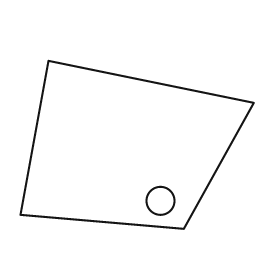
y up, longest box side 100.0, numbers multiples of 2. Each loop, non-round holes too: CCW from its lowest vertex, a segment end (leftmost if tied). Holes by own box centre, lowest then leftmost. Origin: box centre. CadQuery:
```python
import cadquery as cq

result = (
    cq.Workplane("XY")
    .moveTo(20.0, -36.0)
    .lineTo(50.0, 18.0)
    .lineTo(-38.0, 36.0)
    .lineTo(-50.0, -30.0)
    .close()
    .moveTo(10.0, -24.0)
    .circle(6.0)
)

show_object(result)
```